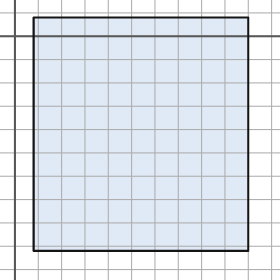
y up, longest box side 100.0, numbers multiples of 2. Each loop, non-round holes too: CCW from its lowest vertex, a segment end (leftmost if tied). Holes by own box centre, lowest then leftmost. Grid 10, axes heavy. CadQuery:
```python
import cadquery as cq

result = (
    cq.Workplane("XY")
    .moveTo(8.0, -92.0)
    .lineTo(100.0, -92.0)
    .lineTo(100.0, 8.0)
    .lineTo(8.0, 8.0)
    .close()
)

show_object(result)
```